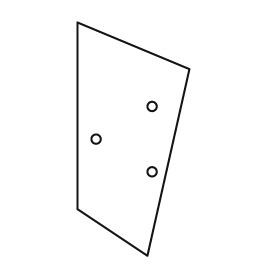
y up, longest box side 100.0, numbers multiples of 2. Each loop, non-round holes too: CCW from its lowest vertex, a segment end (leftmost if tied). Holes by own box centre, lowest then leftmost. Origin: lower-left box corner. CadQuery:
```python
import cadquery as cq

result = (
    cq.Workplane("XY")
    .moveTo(30.0, 0.0)
    .lineTo(48.0, 80.0)
    .lineTo(0.0, 100.0)
    .lineTo(0.0, 20.0)
    .close()
    .moveTo(32.0, 36.0)
    .circle(2.0)
    .moveTo(8.0, 50.0)
    .circle(2.0)
    .moveTo(32.0, 64.0)
    .circle(2.0)
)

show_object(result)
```